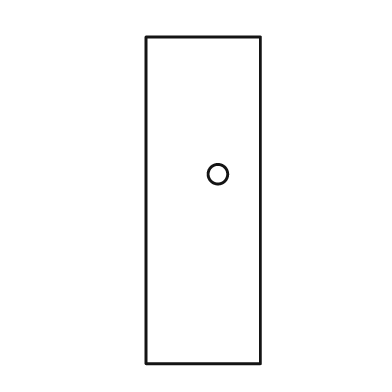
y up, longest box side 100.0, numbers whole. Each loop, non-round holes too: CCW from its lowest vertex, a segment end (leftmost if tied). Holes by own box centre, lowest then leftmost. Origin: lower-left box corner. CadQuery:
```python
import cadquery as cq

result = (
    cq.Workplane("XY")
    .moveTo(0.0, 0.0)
    .lineTo(35.0, 0.0)
    .lineTo(35.0, 100.0)
    .lineTo(0.0, 100.0)
    .close()
    .moveTo(22.0, 58.0)
    .circle(3.0)
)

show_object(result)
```